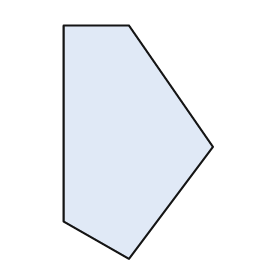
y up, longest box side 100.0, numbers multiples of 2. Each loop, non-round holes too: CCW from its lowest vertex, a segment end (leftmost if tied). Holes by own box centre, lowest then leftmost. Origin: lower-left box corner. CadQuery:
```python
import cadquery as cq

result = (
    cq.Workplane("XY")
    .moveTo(28.0, 0.0)
    .lineTo(64.0, 48.0)
    .lineTo(28.0, 100.0)
    .lineTo(0.0, 100.0)
    .lineTo(0.0, 16.0)
    .close()
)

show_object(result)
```